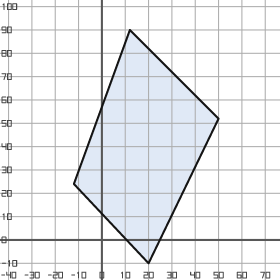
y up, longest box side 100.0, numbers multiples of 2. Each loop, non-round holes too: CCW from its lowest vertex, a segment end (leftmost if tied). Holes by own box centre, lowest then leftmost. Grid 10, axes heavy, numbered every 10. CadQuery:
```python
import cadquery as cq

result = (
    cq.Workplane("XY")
    .moveTo(20.0, -10.0)
    .lineTo(50.0, 52.0)
    .lineTo(12.0, 90.0)
    .lineTo(-12.0, 24.0)
    .close()
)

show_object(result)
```